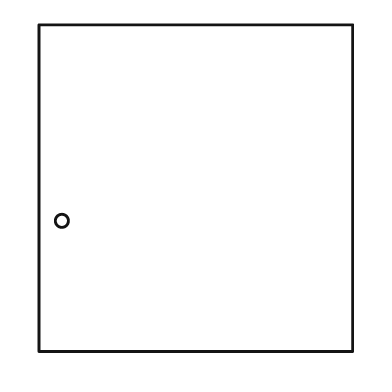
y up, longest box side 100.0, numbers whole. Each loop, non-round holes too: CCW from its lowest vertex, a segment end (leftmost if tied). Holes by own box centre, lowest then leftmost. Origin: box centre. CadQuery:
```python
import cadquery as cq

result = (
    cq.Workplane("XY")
    .moveTo(-48.0, -50.0)
    .lineTo(48.0, -50.0)
    .lineTo(48.0, 50.0)
    .lineTo(-48.0, 50.0)
    .close()
    .moveTo(-41.0, -10.0)
    .circle(2.0)
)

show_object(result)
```